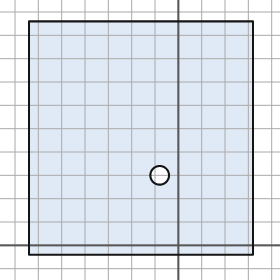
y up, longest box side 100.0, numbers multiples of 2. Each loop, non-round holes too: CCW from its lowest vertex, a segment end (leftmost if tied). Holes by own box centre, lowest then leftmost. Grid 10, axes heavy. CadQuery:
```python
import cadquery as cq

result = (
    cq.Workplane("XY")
    .moveTo(-64.0, -4.0)
    .lineTo(32.0, -4.0)
    .lineTo(32.0, 96.0)
    .lineTo(-64.0, 96.0)
    .close()
    .moveTo(-8.0, 30.0)
    .circle(4.0)
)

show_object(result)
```